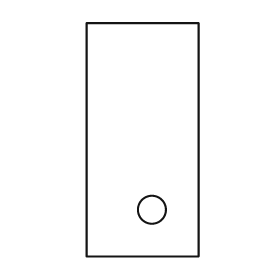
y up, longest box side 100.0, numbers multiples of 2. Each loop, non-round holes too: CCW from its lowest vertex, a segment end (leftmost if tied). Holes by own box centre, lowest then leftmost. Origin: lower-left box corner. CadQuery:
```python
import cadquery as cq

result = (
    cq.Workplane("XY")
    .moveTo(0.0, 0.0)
    .lineTo(48.0, 0.0)
    .lineTo(48.0, 100.0)
    .lineTo(0.0, 100.0)
    .close()
    .moveTo(28.0, 20.0)
    .circle(6.0)
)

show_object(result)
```